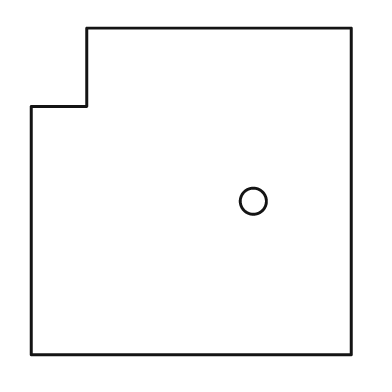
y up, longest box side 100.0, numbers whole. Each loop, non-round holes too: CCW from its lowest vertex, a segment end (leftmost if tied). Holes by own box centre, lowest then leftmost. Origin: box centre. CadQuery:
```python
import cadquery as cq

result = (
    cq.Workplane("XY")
    .moveTo(-49.0, -50.0)
    .lineTo(49.0, -50.0)
    .lineTo(49.0, 50.0)
    .lineTo(-32.0, 50.0)
    .lineTo(-32.0, 26.0)
    .lineTo(-49.0, 26.0)
    .close()
    .moveTo(19.0, -3.0)
    .circle(4.0)
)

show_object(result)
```